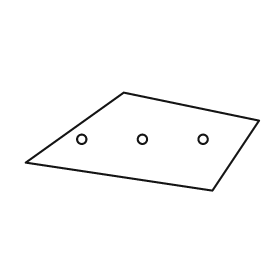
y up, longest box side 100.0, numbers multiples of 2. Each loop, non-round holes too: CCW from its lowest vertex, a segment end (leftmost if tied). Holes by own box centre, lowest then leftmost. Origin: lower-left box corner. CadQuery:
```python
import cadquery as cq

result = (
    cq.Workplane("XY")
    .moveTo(80.0, 0.0)
    .lineTo(100.0, 30.0)
    .lineTo(42.0, 42.0)
    .lineTo(0.0, 12.0)
    .close()
    .moveTo(24.0, 22.0)
    .circle(2.0)
    .moveTo(50.0, 22.0)
    .circle(2.0)
    .moveTo(76.0, 22.0)
    .circle(2.0)
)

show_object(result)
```